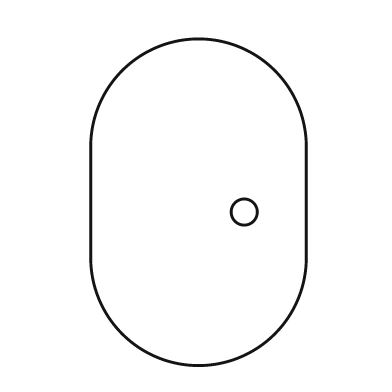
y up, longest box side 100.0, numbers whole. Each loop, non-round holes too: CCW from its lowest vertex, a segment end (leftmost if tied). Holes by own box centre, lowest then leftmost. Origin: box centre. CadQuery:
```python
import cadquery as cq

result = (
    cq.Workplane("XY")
    .moveTo(-33.0, -17.0)
    .threePointArc((0.0, -50.0), (33.0, -17.0))
    .lineTo(33.0, 17.0)
    .threePointArc((0.0, 50.0), (-33.0, 17.0))
    .close()
    .moveTo(14.0, -3.0)
    .circle(4.0)
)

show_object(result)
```